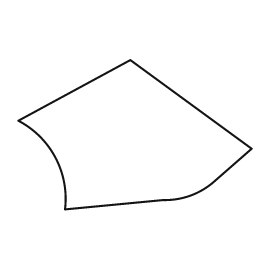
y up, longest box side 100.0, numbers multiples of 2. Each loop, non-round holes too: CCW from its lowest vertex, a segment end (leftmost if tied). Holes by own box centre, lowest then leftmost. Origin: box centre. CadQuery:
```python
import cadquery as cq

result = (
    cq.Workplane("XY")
    .moveTo(-30.0, -32.0)
    .lineTo(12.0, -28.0)
    .threePointArc((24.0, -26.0), (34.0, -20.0))
    .lineTo(50.0, -6.0)
    .lineTo(-2.0, 32.0)
    .lineTo(-50.0, 6.0)
    .threePointArc((-34.0, -10.0), (-30.0, -32.0))
    .close()
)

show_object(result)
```